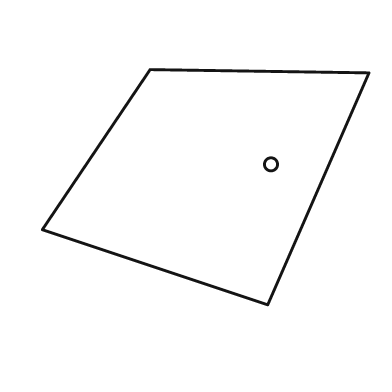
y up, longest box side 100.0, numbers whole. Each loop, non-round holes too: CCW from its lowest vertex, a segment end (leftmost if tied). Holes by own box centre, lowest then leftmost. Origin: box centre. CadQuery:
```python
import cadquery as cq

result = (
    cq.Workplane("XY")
    .moveTo(19.0, -36.0)
    .lineTo(50.0, 35.0)
    .lineTo(-17.0, 36.0)
    .lineTo(-50.0, -13.0)
    .close()
    .moveTo(20.0, 7.0)
    .circle(2.0)
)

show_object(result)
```